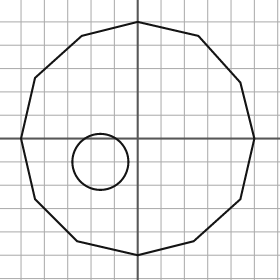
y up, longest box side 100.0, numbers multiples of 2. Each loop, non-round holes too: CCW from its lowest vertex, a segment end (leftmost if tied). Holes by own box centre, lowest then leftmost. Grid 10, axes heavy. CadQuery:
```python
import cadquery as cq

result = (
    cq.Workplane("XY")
    .moveTo(0.0, -50.0)
    .lineTo(24.0, -44.0)
    .lineTo(44.0, -26.0)
    .lineTo(50.0, 0.0)
    .lineTo(44.0, 24.0)
    .lineTo(26.0, 44.0)
    .lineTo(0.0, 50.0)
    .lineTo(-24.0, 44.0)
    .lineTo(-44.0, 26.0)
    .lineTo(-50.0, 0.0)
    .lineTo(-44.0, -26.0)
    .lineTo(-26.0, -44.0)
    .close()
    .moveTo(-16.0, -10.0)
    .circle(12.0)
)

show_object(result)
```